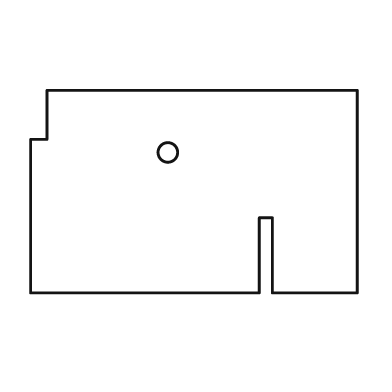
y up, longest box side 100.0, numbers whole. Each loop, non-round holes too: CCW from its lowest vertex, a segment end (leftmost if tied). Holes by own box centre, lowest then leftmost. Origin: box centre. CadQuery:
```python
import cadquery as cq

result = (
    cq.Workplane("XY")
    .moveTo(-50.0, -31.0)
    .lineTo(20.0, -31.0)
    .lineTo(20.0, -8.0)
    .lineTo(24.0, -8.0)
    .lineTo(24.0, -31.0)
    .lineTo(50.0, -31.0)
    .lineTo(50.0, 31.0)
    .lineTo(-45.0, 31.0)
    .lineTo(-45.0, 16.0)
    .lineTo(-50.0, 16.0)
    .close()
    .moveTo(-8.0, 12.0)
    .circle(3.0)
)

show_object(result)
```